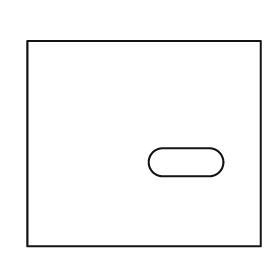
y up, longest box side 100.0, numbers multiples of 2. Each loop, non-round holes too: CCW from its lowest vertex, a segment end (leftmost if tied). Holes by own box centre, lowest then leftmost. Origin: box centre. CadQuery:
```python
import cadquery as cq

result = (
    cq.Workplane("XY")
    .moveTo(-50.0, -44.0)
    .lineTo(50.0, -44.0)
    .lineTo(50.0, 44.0)
    .lineTo(-50.0, 44.0)
    .close()
    .moveTo(8.0, -14.0)
    .lineTo(28.0, -14.0)
    .threePointArc((34.0, -8.0), (28.0, -2.0))
    .lineTo(8.0, -2.0)
    .threePointArc((2.0, -8.0), (8.0, -14.0))
    .close()
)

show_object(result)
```